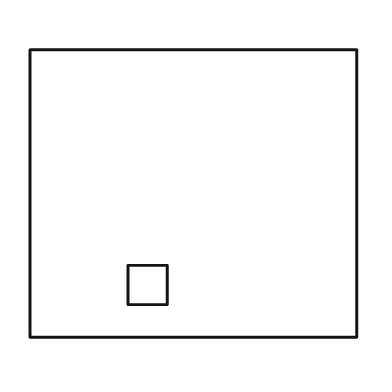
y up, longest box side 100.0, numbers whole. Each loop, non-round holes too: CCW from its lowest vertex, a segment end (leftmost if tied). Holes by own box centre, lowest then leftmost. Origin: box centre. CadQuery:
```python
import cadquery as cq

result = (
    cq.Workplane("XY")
    .moveTo(-50.0, -44.0)
    .lineTo(50.0, -44.0)
    .lineTo(50.0, 44.0)
    .lineTo(-50.0, 44.0)
    .close()
    .moveTo(-20.0, -34.0)
    .lineTo(-8.0, -34.0)
    .lineTo(-8.0, -22.0)
    .lineTo(-20.0, -22.0)
    .close()
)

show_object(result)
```